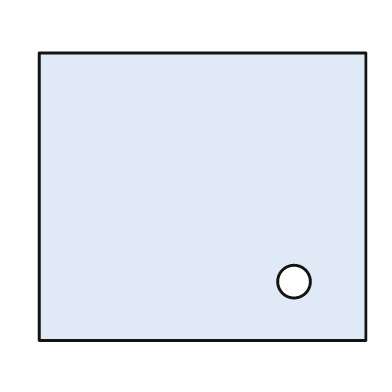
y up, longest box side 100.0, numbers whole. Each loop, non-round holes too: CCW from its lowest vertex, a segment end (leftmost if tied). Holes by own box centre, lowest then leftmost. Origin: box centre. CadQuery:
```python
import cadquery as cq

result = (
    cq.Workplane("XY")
    .moveTo(-50.0, -44.0)
    .lineTo(50.0, -44.0)
    .lineTo(50.0, 44.0)
    .lineTo(-50.0, 44.0)
    .close()
    .moveTo(28.0, -26.0)
    .circle(5.0)
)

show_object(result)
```